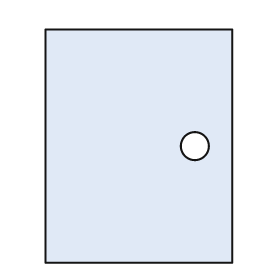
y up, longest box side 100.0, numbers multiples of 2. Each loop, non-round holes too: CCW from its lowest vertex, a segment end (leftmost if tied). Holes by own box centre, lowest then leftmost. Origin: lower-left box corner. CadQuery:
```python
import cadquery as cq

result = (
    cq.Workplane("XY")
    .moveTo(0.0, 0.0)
    .lineTo(80.0, 0.0)
    .lineTo(80.0, 100.0)
    .lineTo(0.0, 100.0)
    .close()
    .moveTo(64.0, 50.0)
    .circle(6.0)
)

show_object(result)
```